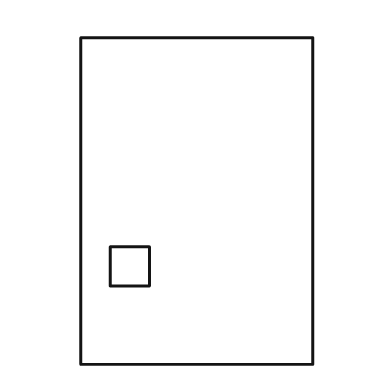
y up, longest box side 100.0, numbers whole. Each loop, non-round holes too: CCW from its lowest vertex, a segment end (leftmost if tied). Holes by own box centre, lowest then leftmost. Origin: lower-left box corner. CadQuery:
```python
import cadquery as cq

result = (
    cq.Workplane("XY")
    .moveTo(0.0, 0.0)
    .lineTo(71.0, 0.0)
    .lineTo(71.0, 100.0)
    .lineTo(0.0, 100.0)
    .close()
    .moveTo(9.0, 24.0)
    .lineTo(21.0, 24.0)
    .lineTo(21.0, 36.0)
    .lineTo(9.0, 36.0)
    .close()
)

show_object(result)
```